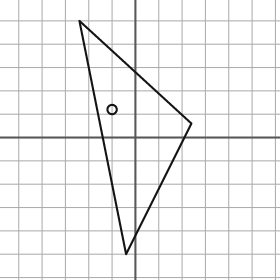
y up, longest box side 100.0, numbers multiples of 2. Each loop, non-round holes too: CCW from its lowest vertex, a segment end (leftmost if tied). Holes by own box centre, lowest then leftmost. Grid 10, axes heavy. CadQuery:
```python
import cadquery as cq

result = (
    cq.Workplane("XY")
    .moveTo(-4.0, -50.0)
    .lineTo(24.0, 6.0)
    .lineTo(-24.0, 50.0)
    .close()
    .moveTo(-10.0, 12.0)
    .circle(2.0)
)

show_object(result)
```